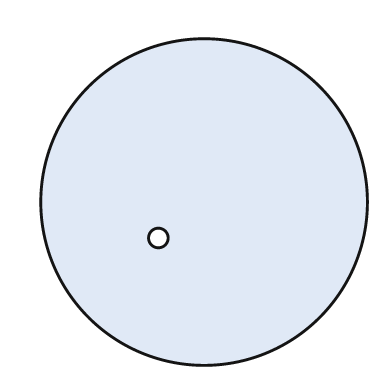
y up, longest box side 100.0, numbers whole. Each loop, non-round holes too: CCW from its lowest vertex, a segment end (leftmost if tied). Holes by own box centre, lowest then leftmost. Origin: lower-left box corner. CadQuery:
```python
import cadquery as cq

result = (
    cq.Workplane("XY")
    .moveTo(50.0, 50.0)
    .circle(50.0)
    .moveTo(36.0, 39.0)
    .circle(3.0)
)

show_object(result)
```